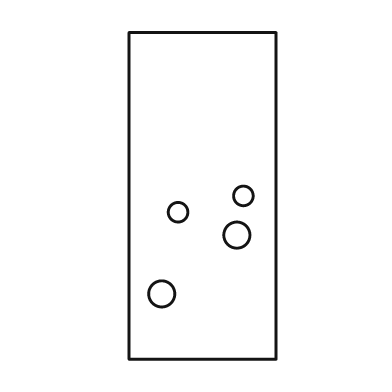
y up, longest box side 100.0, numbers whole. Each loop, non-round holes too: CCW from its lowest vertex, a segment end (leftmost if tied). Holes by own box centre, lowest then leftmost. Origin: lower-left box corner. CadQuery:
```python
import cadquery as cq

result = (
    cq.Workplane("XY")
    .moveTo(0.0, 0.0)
    .lineTo(45.0, 0.0)
    .lineTo(45.0, 100.0)
    .lineTo(0.0, 100.0)
    .close()
    .moveTo(10.0, 20.0)
    .circle(4.0)
    .moveTo(33.0, 38.0)
    .circle(4.0)
    .moveTo(15.0, 45.0)
    .circle(3.0)
    .moveTo(35.0, 50.0)
    .circle(3.0)
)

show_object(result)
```